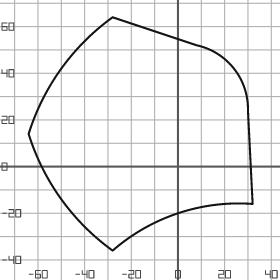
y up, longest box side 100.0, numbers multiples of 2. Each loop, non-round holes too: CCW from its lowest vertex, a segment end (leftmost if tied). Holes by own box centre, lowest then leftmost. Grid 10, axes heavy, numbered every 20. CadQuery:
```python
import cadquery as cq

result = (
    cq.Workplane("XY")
    .moveTo(-28.0, -36.0)
    .threePointArc((0.0, -20.0), (32.0, -16.0))
    .lineTo(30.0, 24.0)
    .threePointArc((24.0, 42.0), (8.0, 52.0))
    .lineTo(-28.0, 64.0)
    .threePointArc((-50.0, 42.0), (-64.0, 14.0))
    .threePointArc((-50.0, -14.0), (-28.0, -36.0))
    .close()
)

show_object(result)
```